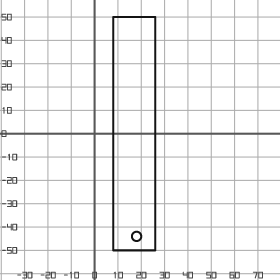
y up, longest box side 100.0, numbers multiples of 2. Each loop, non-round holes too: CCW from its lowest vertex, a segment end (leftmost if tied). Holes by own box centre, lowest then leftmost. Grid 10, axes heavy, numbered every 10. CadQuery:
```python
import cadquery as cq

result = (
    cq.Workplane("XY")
    .moveTo(8.0, -50.0)
    .lineTo(26.0, -50.0)
    .lineTo(26.0, 50.0)
    .lineTo(8.0, 50.0)
    .close()
    .moveTo(18.0, -44.0)
    .circle(2.0)
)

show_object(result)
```